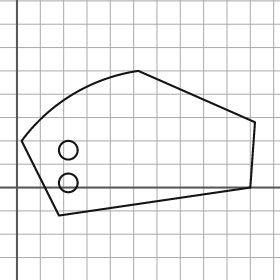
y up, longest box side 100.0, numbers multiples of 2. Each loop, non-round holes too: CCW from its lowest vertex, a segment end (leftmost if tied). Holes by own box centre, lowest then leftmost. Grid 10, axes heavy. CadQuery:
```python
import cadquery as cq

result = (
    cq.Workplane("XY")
    .moveTo(18.0, -12.0)
    .lineTo(100.0, 0.0)
    .lineTo(102.0, 28.0)
    .lineTo(52.0, 50.0)
    .threePointArc((24.0, 40.0), (2.0, 20.0))
    .close()
    .moveTo(22.0, 2.0)
    .circle(4.0)
    .moveTo(22.0, 16.0)
    .circle(4.0)
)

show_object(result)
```